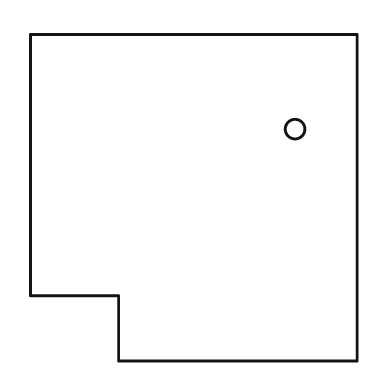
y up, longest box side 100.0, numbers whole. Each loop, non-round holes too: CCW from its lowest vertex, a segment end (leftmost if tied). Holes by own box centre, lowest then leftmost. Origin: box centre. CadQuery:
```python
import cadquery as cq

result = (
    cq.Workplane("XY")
    .moveTo(-23.0, -50.0)
    .lineTo(50.0, -50.0)
    .lineTo(50.0, 50.0)
    .lineTo(-50.0, 50.0)
    .lineTo(-50.0, -30.0)
    .lineTo(-23.0, -30.0)
    .close()
    .moveTo(31.0, 21.0)
    .circle(3.0)
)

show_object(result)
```